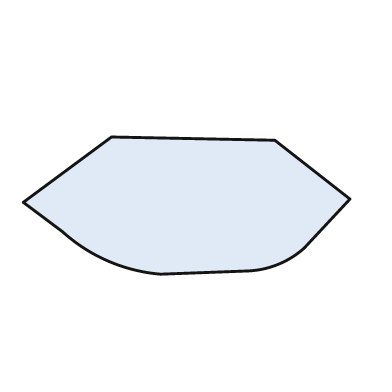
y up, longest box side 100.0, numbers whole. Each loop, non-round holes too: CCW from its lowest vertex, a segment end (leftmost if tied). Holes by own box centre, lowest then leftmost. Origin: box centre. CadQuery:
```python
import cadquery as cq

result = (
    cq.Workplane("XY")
    .moveTo(-8.0, -21.0)
    .lineTo(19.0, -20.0)
    .threePointArc((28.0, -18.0), (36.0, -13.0))
    .lineTo(50.0, 2.0)
    .lineTo(27.0, 20.0)
    .lineTo(-23.0, 21.0)
    .lineTo(-50.0, 1.0)
    .lineTo(-38.0, -8.0)
    .threePointArc((-24.0, -17.0), (-8.0, -21.0))
    .close()
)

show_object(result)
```